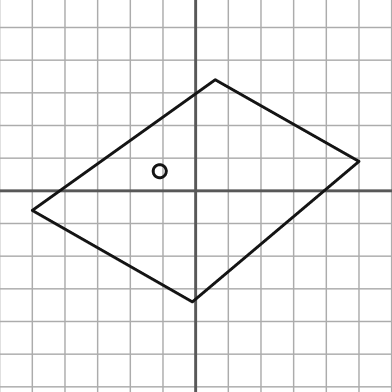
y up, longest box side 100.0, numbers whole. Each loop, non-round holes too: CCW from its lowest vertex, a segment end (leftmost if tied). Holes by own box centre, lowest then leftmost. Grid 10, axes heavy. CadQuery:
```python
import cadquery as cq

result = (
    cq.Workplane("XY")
    .moveTo(-1.0, -34.0)
    .lineTo(50.0, 9.0)
    .lineTo(6.0, 34.0)
    .lineTo(-50.0, -6.0)
    .close()
    .moveTo(-11.0, 6.0)
    .circle(2.0)
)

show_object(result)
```